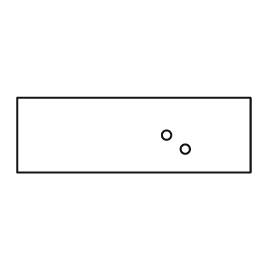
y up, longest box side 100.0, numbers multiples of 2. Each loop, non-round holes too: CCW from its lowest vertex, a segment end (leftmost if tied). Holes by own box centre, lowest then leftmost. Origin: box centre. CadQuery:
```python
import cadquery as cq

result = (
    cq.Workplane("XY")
    .moveTo(-50.0, -16.0)
    .lineTo(50.0, -16.0)
    .lineTo(50.0, 16.0)
    .lineTo(-50.0, 16.0)
    .close()
    .moveTo(22.0, -6.0)
    .circle(2.0)
    .moveTo(14.0, 0.0)
    .circle(2.0)
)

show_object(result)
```